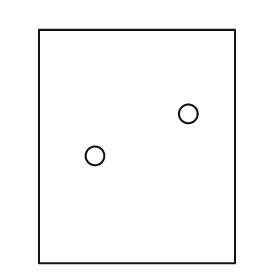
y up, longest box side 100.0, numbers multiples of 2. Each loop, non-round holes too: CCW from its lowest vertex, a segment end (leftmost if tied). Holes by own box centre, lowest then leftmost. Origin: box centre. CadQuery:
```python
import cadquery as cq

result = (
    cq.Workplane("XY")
    .moveTo(-42.0, -50.0)
    .lineTo(42.0, -50.0)
    .lineTo(42.0, 50.0)
    .lineTo(-42.0, 50.0)
    .close()
    .moveTo(-18.0, -4.0)
    .circle(4.0)
    .moveTo(22.0, 14.0)
    .circle(4.0)
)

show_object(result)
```